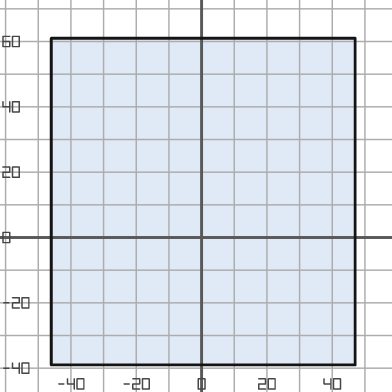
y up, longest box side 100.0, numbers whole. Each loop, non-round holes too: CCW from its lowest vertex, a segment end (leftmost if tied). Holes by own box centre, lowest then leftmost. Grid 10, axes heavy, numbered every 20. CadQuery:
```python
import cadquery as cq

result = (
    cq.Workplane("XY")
    .moveTo(-46.0, -39.0)
    .lineTo(47.0, -39.0)
    .lineTo(47.0, 61.0)
    .lineTo(-46.0, 61.0)
    .close()
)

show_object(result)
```